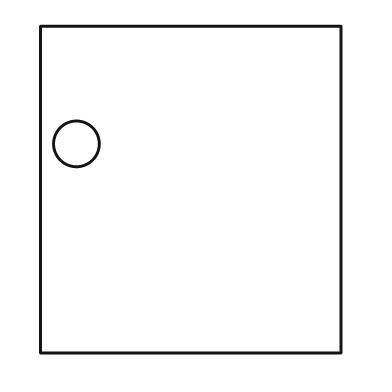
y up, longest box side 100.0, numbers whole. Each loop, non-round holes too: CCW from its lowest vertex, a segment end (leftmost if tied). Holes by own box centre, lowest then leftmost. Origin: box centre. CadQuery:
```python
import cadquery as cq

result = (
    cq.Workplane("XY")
    .moveTo(-46.0, -50.0)
    .lineTo(46.0, -50.0)
    .lineTo(46.0, 50.0)
    .lineTo(-46.0, 50.0)
    .close()
    .moveTo(-35.0, 14.0)
    .circle(7.0)
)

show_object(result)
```